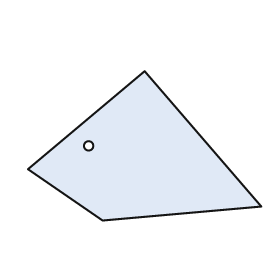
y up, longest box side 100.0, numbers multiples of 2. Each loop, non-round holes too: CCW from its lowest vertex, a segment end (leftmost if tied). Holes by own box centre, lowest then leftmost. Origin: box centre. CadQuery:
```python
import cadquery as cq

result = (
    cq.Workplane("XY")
    .moveTo(-18.0, -32.0)
    .lineTo(50.0, -26.0)
    .lineTo(0.0, 32.0)
    .lineTo(-50.0, -10.0)
    .close()
    .moveTo(-24.0, 0.0)
    .circle(2.0)
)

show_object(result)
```